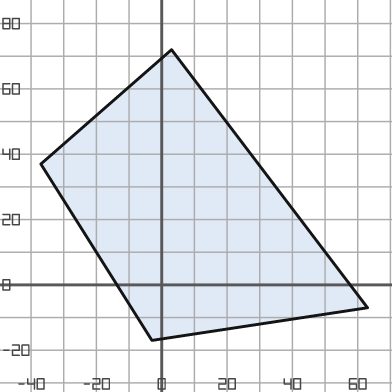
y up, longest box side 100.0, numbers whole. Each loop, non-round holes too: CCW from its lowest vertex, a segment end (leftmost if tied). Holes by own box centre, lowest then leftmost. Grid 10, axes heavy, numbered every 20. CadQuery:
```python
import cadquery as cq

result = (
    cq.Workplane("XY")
    .moveTo(-3.0, -17.0)
    .lineTo(63.0, -7.0)
    .lineTo(3.0, 72.0)
    .lineTo(-37.0, 37.0)
    .close()
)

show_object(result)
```